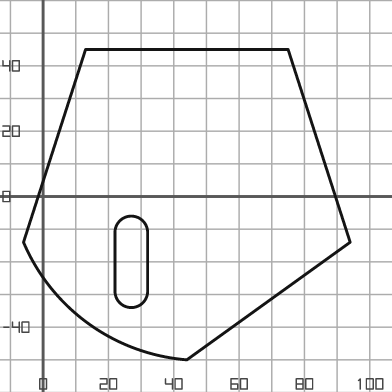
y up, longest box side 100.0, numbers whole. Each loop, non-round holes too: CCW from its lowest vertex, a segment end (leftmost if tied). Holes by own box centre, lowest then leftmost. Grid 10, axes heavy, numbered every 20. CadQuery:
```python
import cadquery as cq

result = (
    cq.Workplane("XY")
    .moveTo(44.0, -50.0)
    .lineTo(94.0, -14.0)
    .lineTo(75.0, 45.0)
    .lineTo(13.0, 45.0)
    .lineTo(-6.0, -14.0)
    .threePointArc((14.0, -39.0), (44.0, -50.0))
    .close()
    .moveTo(22.0, -29.0)
    .threePointArc((27.0, -34.0), (32.0, -29.0))
    .lineTo(32.0, -11.0)
    .threePointArc((27.0, -6.0), (22.0, -11.0))
    .close()
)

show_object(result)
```